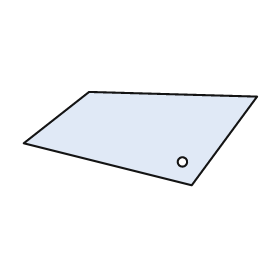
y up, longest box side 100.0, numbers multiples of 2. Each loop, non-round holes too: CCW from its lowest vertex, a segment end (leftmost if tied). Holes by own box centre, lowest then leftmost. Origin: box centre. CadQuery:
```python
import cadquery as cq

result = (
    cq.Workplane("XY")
    .moveTo(22.0, -20.0)
    .lineTo(50.0, 18.0)
    .lineTo(-22.0, 20.0)
    .lineTo(-50.0, -2.0)
    .close()
    .moveTo(18.0, -10.0)
    .circle(2.0)
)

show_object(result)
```